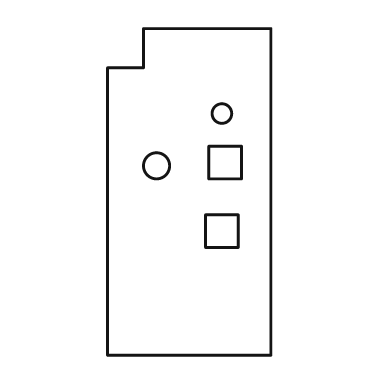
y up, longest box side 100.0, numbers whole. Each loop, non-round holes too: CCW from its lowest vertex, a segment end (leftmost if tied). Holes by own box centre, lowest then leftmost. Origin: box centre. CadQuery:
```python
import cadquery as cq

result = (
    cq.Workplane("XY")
    .moveTo(-25.0, -50.0)
    .lineTo(25.0, -50.0)
    .lineTo(25.0, 50.0)
    .lineTo(-14.0, 50.0)
    .lineTo(-14.0, 38.0)
    .lineTo(-25.0, 38.0)
    .close()
    .moveTo(5.0, -17.0)
    .lineTo(15.0, -17.0)
    .lineTo(15.0, -7.0)
    .lineTo(5.0, -7.0)
    .close()
    .moveTo(-10.0, 8.0)
    .circle(4.0)
    .moveTo(6.0, 4.0)
    .lineTo(16.0, 4.0)
    .lineTo(16.0, 14.0)
    .lineTo(6.0, 14.0)
    .close()
    .moveTo(10.0, 24.0)
    .circle(3.0)
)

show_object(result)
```